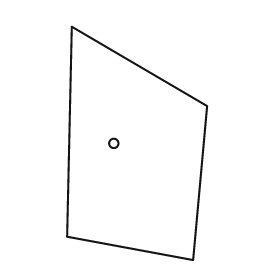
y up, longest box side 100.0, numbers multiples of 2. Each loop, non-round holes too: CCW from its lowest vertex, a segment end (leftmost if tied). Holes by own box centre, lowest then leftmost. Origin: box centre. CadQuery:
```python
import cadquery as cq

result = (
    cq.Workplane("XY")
    .moveTo(24.0, -50.0)
    .lineTo(30.0, 16.0)
    .lineTo(-28.0, 50.0)
    .lineTo(-30.0, -40.0)
    .close()
    .moveTo(-10.0, 0.0)
    .circle(2.0)
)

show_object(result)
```